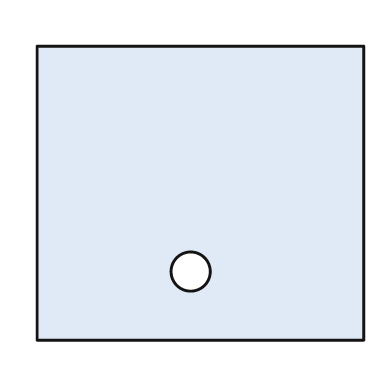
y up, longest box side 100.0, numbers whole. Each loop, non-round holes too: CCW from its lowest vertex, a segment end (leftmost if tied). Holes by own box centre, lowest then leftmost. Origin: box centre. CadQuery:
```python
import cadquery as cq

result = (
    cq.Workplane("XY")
    .moveTo(-50.0, -45.0)
    .lineTo(50.0, -45.0)
    .lineTo(50.0, 45.0)
    .lineTo(-50.0, 45.0)
    .close()
    .moveTo(-3.0, -24.0)
    .circle(6.0)
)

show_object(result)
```